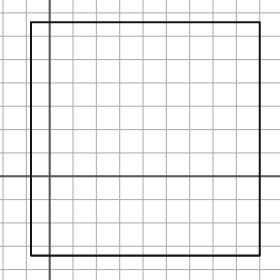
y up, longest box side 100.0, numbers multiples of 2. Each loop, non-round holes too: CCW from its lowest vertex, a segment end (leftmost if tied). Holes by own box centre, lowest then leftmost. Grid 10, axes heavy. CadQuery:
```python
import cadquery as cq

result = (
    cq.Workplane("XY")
    .moveTo(-8.0, -34.0)
    .lineTo(90.0, -34.0)
    .lineTo(90.0, 66.0)
    .lineTo(-8.0, 66.0)
    .close()
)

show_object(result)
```